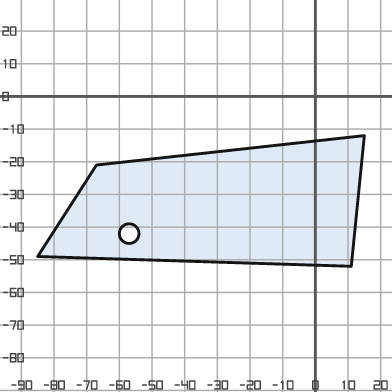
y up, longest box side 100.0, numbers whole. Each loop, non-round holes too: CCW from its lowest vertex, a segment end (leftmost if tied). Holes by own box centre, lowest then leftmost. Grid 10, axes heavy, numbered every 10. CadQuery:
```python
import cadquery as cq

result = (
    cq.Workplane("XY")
    .moveTo(11.0, -52.0)
    .lineTo(15.0, -12.0)
    .lineTo(-67.0, -21.0)
    .lineTo(-85.0, -49.0)
    .close()
    .moveTo(-57.0, -42.0)
    .circle(3.0)
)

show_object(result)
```